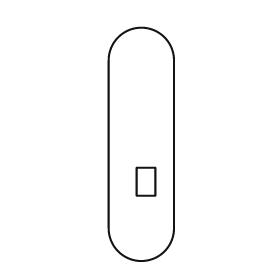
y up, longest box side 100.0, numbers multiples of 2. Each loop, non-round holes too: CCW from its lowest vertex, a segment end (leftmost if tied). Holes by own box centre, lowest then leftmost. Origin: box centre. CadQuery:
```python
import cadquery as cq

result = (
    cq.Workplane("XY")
    .moveTo(-14.0, -36.0)
    .threePointArc((0.0, -50.0), (14.0, -36.0))
    .lineTo(14.0, 36.0)
    .threePointArc((0.0, 50.0), (-14.0, 36.0))
    .close()
    .moveTo(-2.0, -22.0)
    .lineTo(6.0, -22.0)
    .lineTo(6.0, -10.0)
    .lineTo(-2.0, -10.0)
    .close()
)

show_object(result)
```